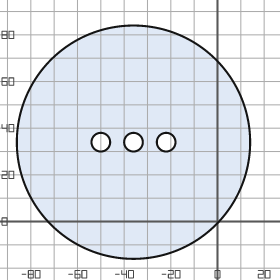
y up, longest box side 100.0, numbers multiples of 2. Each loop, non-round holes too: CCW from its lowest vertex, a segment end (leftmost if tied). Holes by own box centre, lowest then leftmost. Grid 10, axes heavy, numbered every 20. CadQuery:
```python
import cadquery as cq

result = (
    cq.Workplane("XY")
    .moveTo(-36.0, 34.0)
    .circle(50.0)
    .moveTo(-50.0, 34.0)
    .circle(4.0)
    .moveTo(-36.0, 34.0)
    .circle(4.0)
    .moveTo(-22.0, 34.0)
    .circle(4.0)
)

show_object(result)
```